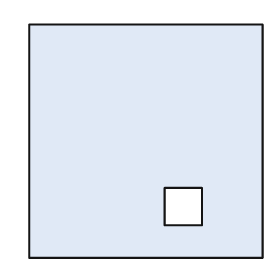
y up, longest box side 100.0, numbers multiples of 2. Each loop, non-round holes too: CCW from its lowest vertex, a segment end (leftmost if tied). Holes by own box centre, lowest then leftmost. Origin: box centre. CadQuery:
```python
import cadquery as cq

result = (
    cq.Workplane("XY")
    .moveTo(-50.0, -50.0)
    .lineTo(50.0, -50.0)
    .lineTo(50.0, 50.0)
    .lineTo(-50.0, 50.0)
    .close()
    .moveTo(8.0, -36.0)
    .lineTo(24.0, -36.0)
    .lineTo(24.0, -20.0)
    .lineTo(8.0, -20.0)
    .close()
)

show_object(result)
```